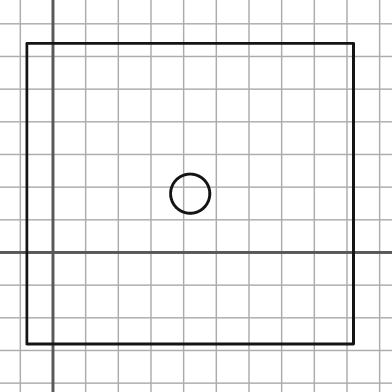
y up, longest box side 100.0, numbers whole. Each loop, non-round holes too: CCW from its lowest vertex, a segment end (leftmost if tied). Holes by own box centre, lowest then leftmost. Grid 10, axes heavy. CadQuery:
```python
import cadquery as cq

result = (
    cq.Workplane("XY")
    .moveTo(-8.0, -28.0)
    .lineTo(92.0, -28.0)
    .lineTo(92.0, 64.0)
    .lineTo(-8.0, 64.0)
    .close()
    .moveTo(42.0, 18.0)
    .circle(6.0)
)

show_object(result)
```